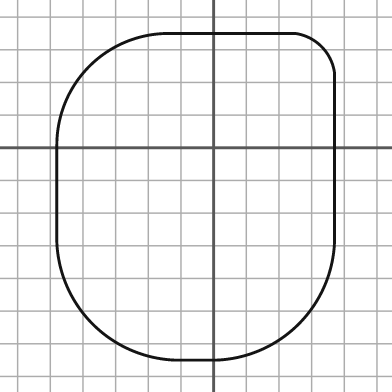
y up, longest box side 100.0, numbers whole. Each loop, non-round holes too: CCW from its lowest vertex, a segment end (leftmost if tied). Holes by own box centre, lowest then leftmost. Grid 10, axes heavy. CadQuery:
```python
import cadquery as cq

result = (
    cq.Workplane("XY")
    .moveTo(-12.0, -65.0)
    .lineTo(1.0, -65.0)
    .threePointArc((26.0, -54.0), (37.0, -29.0))
    .lineTo(37.0, 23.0)
    .threePointArc((33.0, 31.0), (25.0, 35.0))
    .lineTo(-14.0, 35.0)
    .threePointArc((-38.0, 25.0), (-48.0, 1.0))
    .lineTo(-48.0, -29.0)
    .threePointArc((-37.0, -54.0), (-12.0, -65.0))
    .close()
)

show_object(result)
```